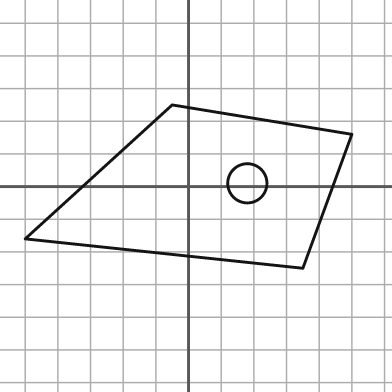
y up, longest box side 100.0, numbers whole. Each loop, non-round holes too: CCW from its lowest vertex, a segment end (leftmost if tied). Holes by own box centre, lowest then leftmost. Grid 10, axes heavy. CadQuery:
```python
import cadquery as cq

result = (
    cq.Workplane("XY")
    .moveTo(35.0, -25.0)
    .lineTo(50.0, 16.0)
    .lineTo(-5.0, 25.0)
    .lineTo(-50.0, -16.0)
    .close()
    .moveTo(18.0, 1.0)
    .circle(6.0)
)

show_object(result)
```